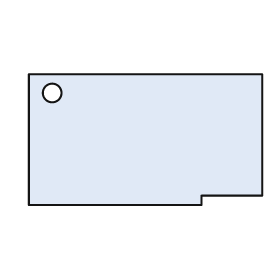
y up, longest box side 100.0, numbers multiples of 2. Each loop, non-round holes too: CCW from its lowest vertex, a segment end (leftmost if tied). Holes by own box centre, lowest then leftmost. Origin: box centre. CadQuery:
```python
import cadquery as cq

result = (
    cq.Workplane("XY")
    .moveTo(-50.0, -28.0)
    .lineTo(24.0, -28.0)
    .lineTo(24.0, -24.0)
    .lineTo(50.0, -24.0)
    .lineTo(50.0, 28.0)
    .lineTo(-50.0, 28.0)
    .close()
    .moveTo(-40.0, 20.0)
    .circle(4.0)
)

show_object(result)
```